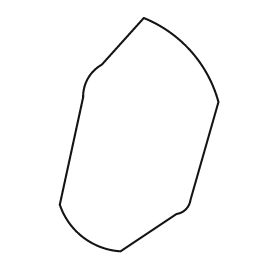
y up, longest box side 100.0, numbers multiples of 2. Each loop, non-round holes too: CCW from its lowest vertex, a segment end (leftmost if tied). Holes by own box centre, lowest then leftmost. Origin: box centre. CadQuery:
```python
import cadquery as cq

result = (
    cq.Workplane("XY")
    .moveTo(-8.0, -50.0)
    .lineTo(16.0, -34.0)
    .threePointArc((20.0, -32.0), (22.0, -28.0))
    .lineTo(34.0, 14.0)
    .threePointArc((22.0, 36.0), (2.0, 50.0))
    .lineTo(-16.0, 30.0)
    .threePointArc((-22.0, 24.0), (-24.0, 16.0))
    .lineTo(-34.0, -30.0)
    .threePointArc((-24.0, -44.0), (-8.0, -50.0))
    .close()
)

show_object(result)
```